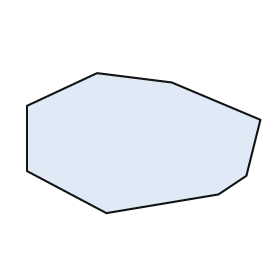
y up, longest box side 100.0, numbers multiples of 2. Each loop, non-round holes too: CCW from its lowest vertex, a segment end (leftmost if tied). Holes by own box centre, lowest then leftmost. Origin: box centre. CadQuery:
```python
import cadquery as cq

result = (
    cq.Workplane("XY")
    .moveTo(-16.0, -30.0)
    .lineTo(32.0, -22.0)
    .lineTo(44.0, -14.0)
    .lineTo(50.0, 10.0)
    .lineTo(12.0, 26.0)
    .lineTo(-20.0, 30.0)
    .lineTo(-50.0, 16.0)
    .lineTo(-50.0, -12.0)
    .close()
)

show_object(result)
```